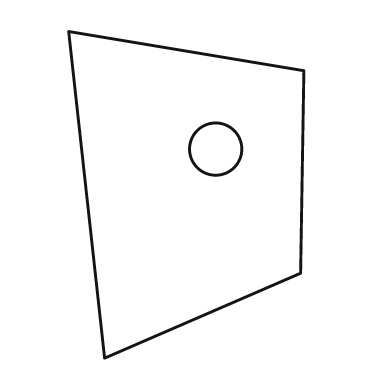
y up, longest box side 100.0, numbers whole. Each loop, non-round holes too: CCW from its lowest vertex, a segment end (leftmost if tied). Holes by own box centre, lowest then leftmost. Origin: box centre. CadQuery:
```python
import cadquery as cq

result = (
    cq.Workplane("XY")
    .moveTo(-25.0, -50.0)
    .lineTo(35.0, -24.0)
    .lineTo(36.0, 38.0)
    .lineTo(-36.0, 50.0)
    .close()
    .moveTo(9.0, 14.0)
    .circle(8.0)
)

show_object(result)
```